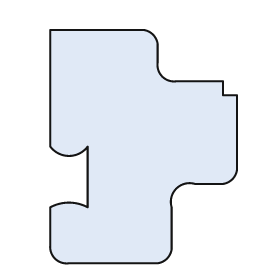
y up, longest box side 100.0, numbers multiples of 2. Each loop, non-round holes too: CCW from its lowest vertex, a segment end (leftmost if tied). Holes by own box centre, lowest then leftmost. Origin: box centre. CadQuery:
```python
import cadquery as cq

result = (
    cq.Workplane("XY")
    .moveTo(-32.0, -50.0)
    .lineTo(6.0, -50.0)
    .threePointArc((10.0, -48.0), (12.0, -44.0))
    .lineTo(12.0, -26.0)
    .threePointArc((14.0, -18.0), (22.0, -16.0))
    .lineTo(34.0, -16.0)
    .threePointArc((38.0, -14.0), (40.0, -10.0))
    .lineTo(40.0, 22.0)
    .lineTo(34.0, 22.0)
    .lineTo(34.0, 28.0)
    .lineTo(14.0, 28.0)
    .threePointArc((8.0, 30.0), (6.0, 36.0))
    .lineTo(6.0, 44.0)
    .threePointArc((4.0, 48.0), (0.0, 50.0))
    .lineTo(-40.0, 50.0)
    .lineTo(-40.0, 0.0)
    .threePointArc((-32.0, -4.0), (-24.0, 0.0))
    .lineTo(-24.0, -26.0)
    .threePointArc((-32.0, -24.0), (-40.0, -26.0))
    .lineTo(-40.0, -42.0)
    .threePointArc((-38.0, -48.0), (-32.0, -50.0))
    .close()
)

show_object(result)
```